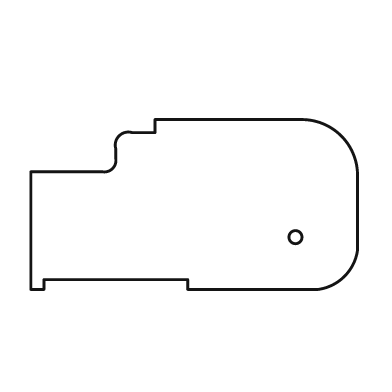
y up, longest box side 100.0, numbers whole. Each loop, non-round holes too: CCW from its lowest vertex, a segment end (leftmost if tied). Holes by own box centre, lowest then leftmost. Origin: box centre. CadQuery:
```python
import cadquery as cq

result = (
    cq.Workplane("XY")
    .moveTo(-50.0, -26.0)
    .lineTo(-46.0, -26.0)
    .lineTo(-46.0, -23.0)
    .lineTo(-2.0, -23.0)
    .lineTo(-2.0, -26.0)
    .lineTo(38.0, -26.0)
    .threePointArc((46.0, -22.0), (50.0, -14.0))
    .lineTo(50.0, 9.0)
    .threePointArc((45.0, 21.0), (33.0, 26.0))
    .lineTo(-12.0, 26.0)
    .lineTo(-12.0, 22.0)
    .lineTo(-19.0, 22.0)
    .threePointArc((-23.0, 21.0), (-24.0, 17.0))
    .lineTo(-24.0, 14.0)
    .threePointArc((-25.0, 11.0), (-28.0, 10.0))
    .lineTo(-50.0, 10.0)
    .close()
    .moveTo(31.0, -10.0)
    .circle(2.0)
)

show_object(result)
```